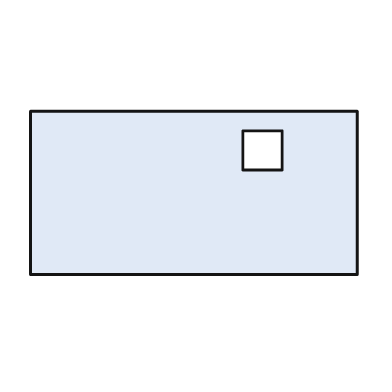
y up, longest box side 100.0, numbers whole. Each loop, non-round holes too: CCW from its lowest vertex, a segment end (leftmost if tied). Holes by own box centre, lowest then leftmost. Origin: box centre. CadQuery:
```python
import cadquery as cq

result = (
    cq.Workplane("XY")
    .moveTo(-50.0, -25.0)
    .lineTo(50.0, -25.0)
    .lineTo(50.0, 25.0)
    .lineTo(-50.0, 25.0)
    .close()
    .moveTo(15.0, 7.0)
    .lineTo(27.0, 7.0)
    .lineTo(27.0, 19.0)
    .lineTo(15.0, 19.0)
    .close()
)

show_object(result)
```